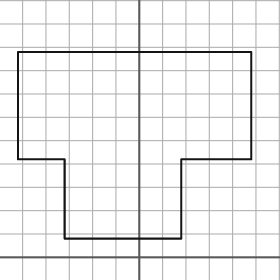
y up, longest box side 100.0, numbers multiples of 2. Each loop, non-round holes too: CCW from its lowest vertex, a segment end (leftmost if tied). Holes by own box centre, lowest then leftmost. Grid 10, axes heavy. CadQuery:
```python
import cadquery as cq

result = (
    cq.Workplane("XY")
    .moveTo(-32.0, 8.0)
    .lineTo(18.0, 8.0)
    .lineTo(18.0, 42.0)
    .lineTo(48.0, 42.0)
    .lineTo(48.0, 88.0)
    .lineTo(-52.0, 88.0)
    .lineTo(-52.0, 42.0)
    .lineTo(-32.0, 42.0)
    .close()
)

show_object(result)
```